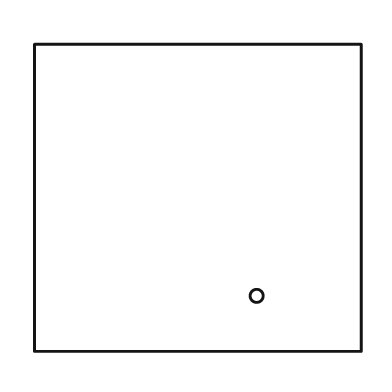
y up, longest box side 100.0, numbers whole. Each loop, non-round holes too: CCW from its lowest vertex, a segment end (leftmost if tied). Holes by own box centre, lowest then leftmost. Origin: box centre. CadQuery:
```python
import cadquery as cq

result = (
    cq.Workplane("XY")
    .moveTo(-50.0, -47.0)
    .lineTo(50.0, -47.0)
    .lineTo(50.0, 47.0)
    .lineTo(-50.0, 47.0)
    .close()
    .moveTo(18.0, -30.0)
    .circle(2.0)
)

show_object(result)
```